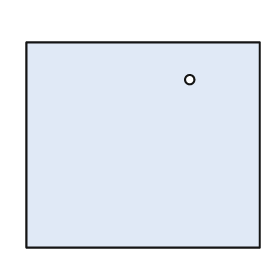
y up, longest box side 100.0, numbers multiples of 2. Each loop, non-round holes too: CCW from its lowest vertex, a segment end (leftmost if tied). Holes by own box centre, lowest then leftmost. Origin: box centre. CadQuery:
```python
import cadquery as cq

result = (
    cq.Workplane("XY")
    .moveTo(-50.0, -44.0)
    .lineTo(50.0, -44.0)
    .lineTo(50.0, 44.0)
    .lineTo(-50.0, 44.0)
    .close()
    .moveTo(20.0, 28.0)
    .circle(2.0)
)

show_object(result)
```